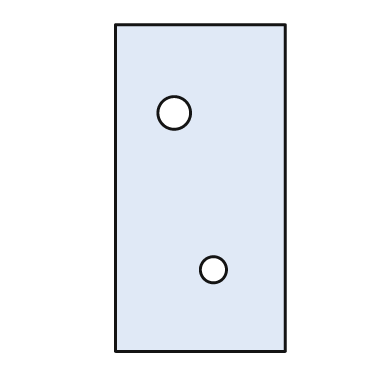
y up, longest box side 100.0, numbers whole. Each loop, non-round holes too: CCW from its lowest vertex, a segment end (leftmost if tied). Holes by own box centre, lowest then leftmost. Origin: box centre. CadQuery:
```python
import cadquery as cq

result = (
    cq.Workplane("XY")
    .moveTo(-26.0, -50.0)
    .lineTo(26.0, -50.0)
    .lineTo(26.0, 50.0)
    .lineTo(-26.0, 50.0)
    .close()
    .moveTo(4.0, -25.0)
    .circle(4.0)
    .moveTo(-8.0, 23.0)
    .circle(5.0)
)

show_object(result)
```